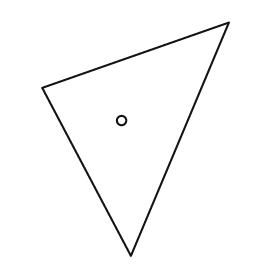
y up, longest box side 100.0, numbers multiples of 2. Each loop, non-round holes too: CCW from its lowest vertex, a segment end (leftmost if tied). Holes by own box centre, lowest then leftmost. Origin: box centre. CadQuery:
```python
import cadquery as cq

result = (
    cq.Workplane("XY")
    .moveTo(-2.0, -50.0)
    .lineTo(40.0, 50.0)
    .lineTo(-40.0, 22.0)
    .close()
    .moveTo(-6.0, 8.0)
    .circle(2.0)
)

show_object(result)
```